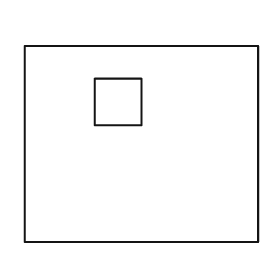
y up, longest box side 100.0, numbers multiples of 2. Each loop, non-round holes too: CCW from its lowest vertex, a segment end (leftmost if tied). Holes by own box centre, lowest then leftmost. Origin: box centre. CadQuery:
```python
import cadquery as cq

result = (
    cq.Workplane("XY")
    .moveTo(-50.0, -42.0)
    .lineTo(50.0, -42.0)
    .lineTo(50.0, 42.0)
    .lineTo(-50.0, 42.0)
    .close()
    .moveTo(-20.0, 8.0)
    .lineTo(0.0, 8.0)
    .lineTo(0.0, 28.0)
    .lineTo(-20.0, 28.0)
    .close()
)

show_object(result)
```